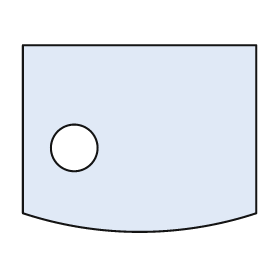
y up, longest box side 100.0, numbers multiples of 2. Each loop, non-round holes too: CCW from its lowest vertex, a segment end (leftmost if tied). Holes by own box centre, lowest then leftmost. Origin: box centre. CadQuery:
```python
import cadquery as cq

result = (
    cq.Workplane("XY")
    .moveTo(-50.0, -32.0)
    .threePointArc((0.0, -40.0), (50.0, -32.0))
    .lineTo(50.0, 40.0)
    .lineTo(-50.0, 40.0)
    .close()
    .moveTo(-28.0, -4.0)
    .circle(10.0)
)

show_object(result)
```